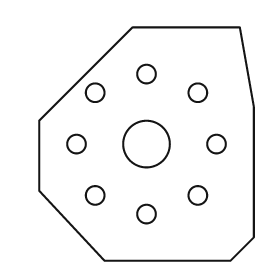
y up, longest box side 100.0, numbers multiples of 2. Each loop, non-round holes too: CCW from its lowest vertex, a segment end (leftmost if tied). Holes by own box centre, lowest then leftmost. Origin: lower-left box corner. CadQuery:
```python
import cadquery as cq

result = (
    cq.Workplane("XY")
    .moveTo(28.0, 0.0)
    .lineTo(82.0, 0.0)
    .lineTo(92.0, 10.0)
    .lineTo(92.0, 66.0)
    .lineTo(86.0, 100.0)
    .lineTo(40.0, 100.0)
    .lineTo(0.0, 60.0)
    .lineTo(0.0, 30.0)
    .close()
    .moveTo(46.0, 20.0)
    .circle(4.0)
    .moveTo(24.0, 28.0)
    .circle(4.0)
    .moveTo(68.0, 28.0)
    .circle(4.0)
    .moveTo(16.0, 50.0)
    .circle(4.0)
    .moveTo(46.0, 50.0)
    .circle(10.0)
    .moveTo(76.0, 50.0)
    .circle(4.0)
    .moveTo(24.0, 72.0)
    .circle(4.0)
    .moveTo(68.0, 72.0)
    .circle(4.0)
    .moveTo(46.0, 80.0)
    .circle(4.0)
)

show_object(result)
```